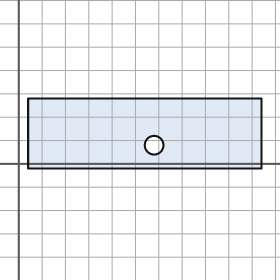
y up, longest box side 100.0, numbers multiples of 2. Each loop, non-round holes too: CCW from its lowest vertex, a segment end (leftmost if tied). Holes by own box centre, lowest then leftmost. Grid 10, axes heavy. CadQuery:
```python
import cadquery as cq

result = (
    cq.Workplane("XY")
    .moveTo(4.0, -2.0)
    .lineTo(104.0, -2.0)
    .lineTo(104.0, 28.0)
    .lineTo(4.0, 28.0)
    .close()
    .moveTo(58.0, 8.0)
    .circle(4.0)
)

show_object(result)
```